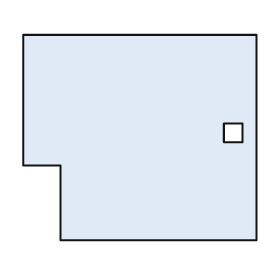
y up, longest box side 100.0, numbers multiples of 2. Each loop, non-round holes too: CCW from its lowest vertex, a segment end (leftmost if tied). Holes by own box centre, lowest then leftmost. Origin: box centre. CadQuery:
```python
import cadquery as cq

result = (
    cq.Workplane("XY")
    .moveTo(-34.0, -44.0)
    .lineTo(50.0, -44.0)
    .lineTo(50.0, 44.0)
    .lineTo(-50.0, 44.0)
    .lineTo(-50.0, -12.0)
    .lineTo(-34.0, -12.0)
    .close()
    .moveTo(36.0, -2.0)
    .lineTo(44.0, -2.0)
    .lineTo(44.0, 6.0)
    .lineTo(36.0, 6.0)
    .close()
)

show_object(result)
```